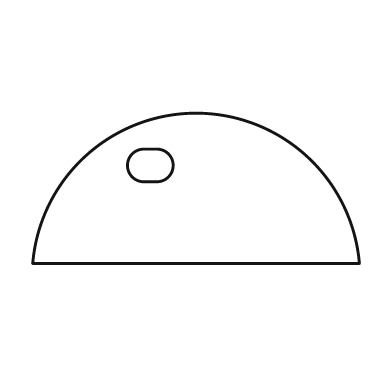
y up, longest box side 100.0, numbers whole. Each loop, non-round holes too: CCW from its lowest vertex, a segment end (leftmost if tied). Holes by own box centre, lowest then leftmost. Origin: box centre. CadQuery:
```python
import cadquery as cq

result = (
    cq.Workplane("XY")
    .moveTo(-50.0, -23.0)
    .lineTo(50.0, -23.0)
    .threePointArc((0.0, 23.0), (-50.0, -23.0))
    .close()
    .moveTo(-16.0, 2.0)
    .lineTo(-12.0, 2.0)
    .threePointArc((-7.0, 7.0), (-12.0, 12.0))
    .lineTo(-16.0, 12.0)
    .threePointArc((-21.0, 7.0), (-16.0, 2.0))
    .close()
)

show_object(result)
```